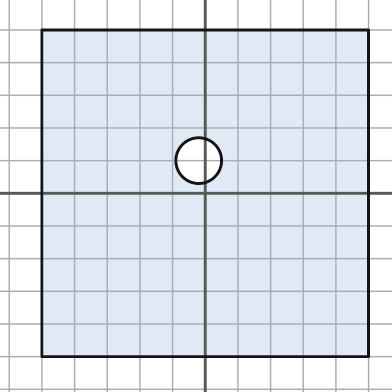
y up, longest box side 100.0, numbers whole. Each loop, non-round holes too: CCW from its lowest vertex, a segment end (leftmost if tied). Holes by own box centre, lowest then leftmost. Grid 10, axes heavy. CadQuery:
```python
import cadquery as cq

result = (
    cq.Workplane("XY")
    .moveTo(-50.0, -50.0)
    .lineTo(50.0, -50.0)
    .lineTo(50.0, 50.0)
    .lineTo(-50.0, 50.0)
    .close()
    .moveTo(-2.0, 10.0)
    .circle(7.0)
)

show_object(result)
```